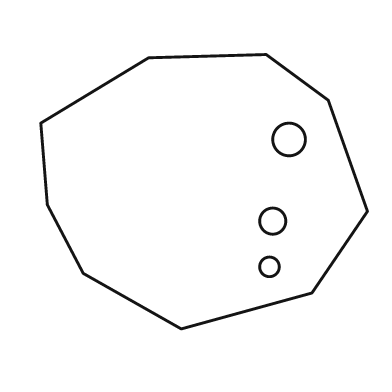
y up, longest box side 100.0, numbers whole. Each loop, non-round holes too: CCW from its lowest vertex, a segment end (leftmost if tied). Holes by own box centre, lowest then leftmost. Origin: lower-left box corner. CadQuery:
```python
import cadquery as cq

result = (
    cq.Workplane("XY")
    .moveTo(43.0, 0.0)
    .lineTo(83.0, 11.0)
    .lineTo(100.0, 36.0)
    .lineTo(88.0, 70.0)
    .lineTo(69.0, 84.0)
    .lineTo(33.0, 83.0)
    .lineTo(0.0, 63.0)
    .lineTo(2.0, 38.0)
    .lineTo(13.0, 17.0)
    .close()
    .moveTo(70.0, 19.0)
    .circle(3.0)
    .moveTo(71.0, 33.0)
    .circle(4.0)
    .moveTo(76.0, 58.0)
    .circle(5.0)
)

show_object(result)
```